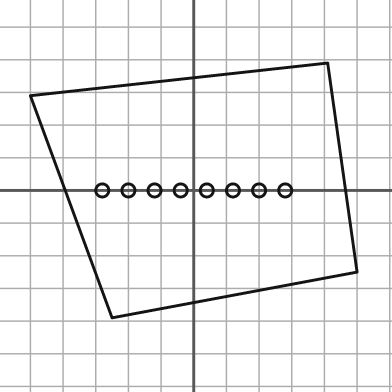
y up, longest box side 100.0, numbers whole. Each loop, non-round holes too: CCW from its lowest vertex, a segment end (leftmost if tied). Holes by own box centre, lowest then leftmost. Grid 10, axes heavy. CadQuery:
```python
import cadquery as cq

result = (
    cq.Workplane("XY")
    .moveTo(-25.0, -39.0)
    .lineTo(50.0, -25.0)
    .lineTo(41.0, 39.0)
    .lineTo(-50.0, 29.0)
    .close()
    .moveTo(-28.0, 0.0)
    .circle(2.0)
    .moveTo(-20.0, 0.0)
    .circle(2.0)
    .moveTo(-12.0, 0.0)
    .circle(2.0)
    .moveTo(-4.0, 0.0)
    .circle(2.0)
    .moveTo(4.0, 0.0)
    .circle(2.0)
    .moveTo(12.0, 0.0)
    .circle(2.0)
    .moveTo(20.0, 0.0)
    .circle(2.0)
    .moveTo(28.0, 0.0)
    .circle(2.0)
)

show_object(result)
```